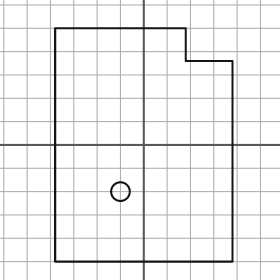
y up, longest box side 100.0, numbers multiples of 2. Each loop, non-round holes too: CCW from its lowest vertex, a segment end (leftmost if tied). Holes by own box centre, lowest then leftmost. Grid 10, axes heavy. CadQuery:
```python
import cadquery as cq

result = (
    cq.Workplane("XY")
    .moveTo(-38.0, -50.0)
    .lineTo(38.0, -50.0)
    .lineTo(38.0, 36.0)
    .lineTo(18.0, 36.0)
    .lineTo(18.0, 50.0)
    .lineTo(-38.0, 50.0)
    .close()
    .moveTo(-10.0, -20.0)
    .circle(4.0)
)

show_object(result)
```